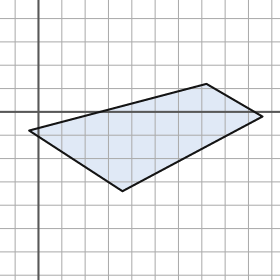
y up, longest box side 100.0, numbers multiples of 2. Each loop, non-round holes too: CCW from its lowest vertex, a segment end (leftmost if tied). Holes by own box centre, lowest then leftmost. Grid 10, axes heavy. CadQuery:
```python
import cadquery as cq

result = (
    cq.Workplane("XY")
    .moveTo(36.0, -34.0)
    .lineTo(96.0, -2.0)
    .lineTo(72.0, 12.0)
    .lineTo(-4.0, -8.0)
    .close()
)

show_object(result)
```